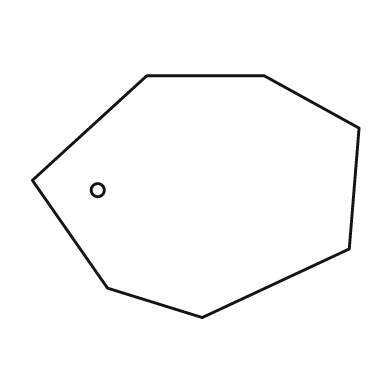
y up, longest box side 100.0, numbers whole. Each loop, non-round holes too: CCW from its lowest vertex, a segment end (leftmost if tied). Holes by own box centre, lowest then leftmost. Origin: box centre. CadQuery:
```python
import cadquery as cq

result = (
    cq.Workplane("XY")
    .moveTo(2.0, -37.0)
    .lineTo(47.0, -16.0)
    .lineTo(50.0, 21.0)
    .lineTo(21.0, 37.0)
    .lineTo(-15.0, 37.0)
    .lineTo(-50.0, 5.0)
    .lineTo(-27.0, -28.0)
    .close()
    .moveTo(-30.0, 2.0)
    .circle(2.0)
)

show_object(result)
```